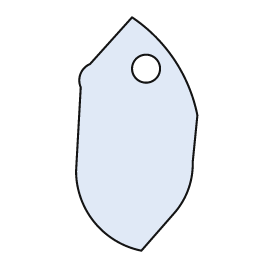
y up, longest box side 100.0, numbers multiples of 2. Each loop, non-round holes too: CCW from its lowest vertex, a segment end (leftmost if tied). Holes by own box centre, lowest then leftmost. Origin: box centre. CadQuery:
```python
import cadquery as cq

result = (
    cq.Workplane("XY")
    .moveTo(2.0, -50.0)
    .lineTo(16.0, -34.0)
    .threePointArc((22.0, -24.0), (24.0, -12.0))
    .lineTo(26.0, 8.0)
    .threePointArc((16.0, 32.0), (-2.0, 50.0))
    .lineTo(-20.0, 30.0)
    .threePointArc((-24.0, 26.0), (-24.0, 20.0))
    .lineTo(-26.0, -16.0)
    .threePointArc((-18.0, -38.0), (2.0, -50.0))
    .close()
    .moveTo(4.0, 28.0)
    .circle(6.0)
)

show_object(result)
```